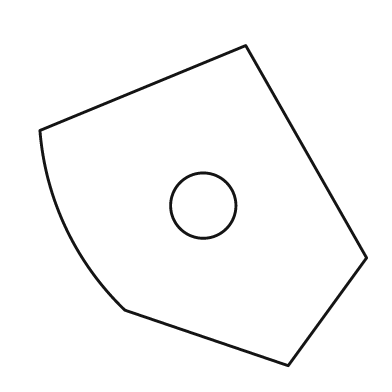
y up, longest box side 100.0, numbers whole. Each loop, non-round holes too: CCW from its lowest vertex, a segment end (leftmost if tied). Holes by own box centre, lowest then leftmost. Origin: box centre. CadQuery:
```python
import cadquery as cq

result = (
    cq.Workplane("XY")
    .moveTo(26.0, -49.0)
    .lineTo(50.0, -16.0)
    .lineTo(13.0, 49.0)
    .lineTo(-50.0, 23.0)
    .threePointArc((-42.0, -7.0), (-24.0, -32.0))
    .close()
    .moveTo(0.0, 0.0)
    .circle(10.0)
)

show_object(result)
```